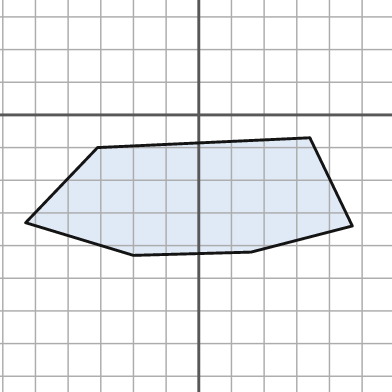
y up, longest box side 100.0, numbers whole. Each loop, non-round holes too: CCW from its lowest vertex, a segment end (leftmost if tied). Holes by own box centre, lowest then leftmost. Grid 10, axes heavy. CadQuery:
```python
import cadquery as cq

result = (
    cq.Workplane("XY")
    .moveTo(-20.0, -43.0)
    .lineTo(16.0, -42.0)
    .lineTo(47.0, -34.0)
    .lineTo(34.0, -7.0)
    .lineTo(-31.0, -10.0)
    .lineTo(-53.0, -33.0)
    .close()
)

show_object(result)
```